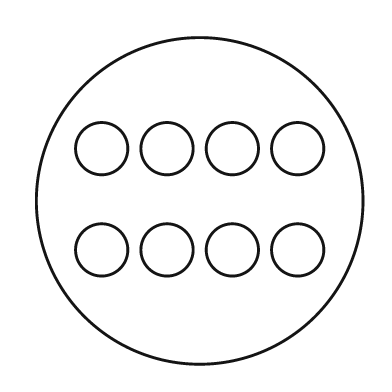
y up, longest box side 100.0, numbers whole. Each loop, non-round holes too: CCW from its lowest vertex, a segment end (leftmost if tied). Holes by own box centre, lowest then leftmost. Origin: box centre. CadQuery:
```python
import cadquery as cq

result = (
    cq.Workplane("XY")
    .moveTo(0.0, 0.0)
    .circle(50.0)
    .moveTo(-30.0, -15.0)
    .circle(8.0)
    .moveTo(-10.0, -15.0)
    .circle(8.0)
    .moveTo(10.0, -15.0)
    .circle(8.0)
    .moveTo(30.0, -15.0)
    .circle(8.0)
    .moveTo(-30.0, 16.0)
    .circle(8.0)
    .moveTo(-10.0, 16.0)
    .circle(8.0)
    .moveTo(10.0, 16.0)
    .circle(8.0)
    .moveTo(30.0, 16.0)
    .circle(8.0)
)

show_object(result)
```